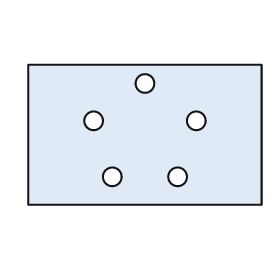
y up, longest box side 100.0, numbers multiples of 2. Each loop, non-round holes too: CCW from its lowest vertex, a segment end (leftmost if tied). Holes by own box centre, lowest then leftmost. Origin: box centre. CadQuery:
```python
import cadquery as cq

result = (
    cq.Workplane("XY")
    .moveTo(-50.0, -30.0)
    .lineTo(50.0, -30.0)
    .lineTo(50.0, 30.0)
    .lineTo(-50.0, 30.0)
    .close()
    .moveTo(-14.0, -18.0)
    .circle(4.0)
    .moveTo(14.0, -18.0)
    .circle(4.0)
    .moveTo(-22.0, 6.0)
    .circle(4.0)
    .moveTo(22.0, 6.0)
    .circle(4.0)
    .moveTo(0.0, 22.0)
    .circle(4.0)
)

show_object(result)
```